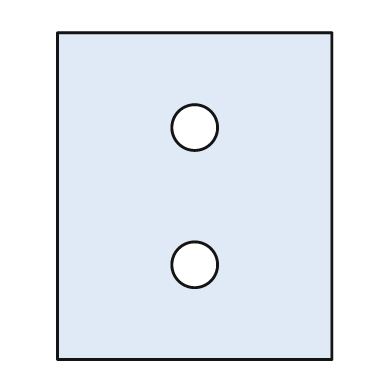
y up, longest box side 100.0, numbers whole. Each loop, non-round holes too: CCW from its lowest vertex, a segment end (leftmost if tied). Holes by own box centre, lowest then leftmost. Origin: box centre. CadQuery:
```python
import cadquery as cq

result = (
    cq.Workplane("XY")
    .moveTo(-42.0, -50.0)
    .lineTo(42.0, -50.0)
    .lineTo(42.0, 50.0)
    .lineTo(-42.0, 50.0)
    .close()
    .moveTo(0.0, -21.0)
    .circle(7.0)
    .moveTo(0.0, 21.0)
    .circle(7.0)
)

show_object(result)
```